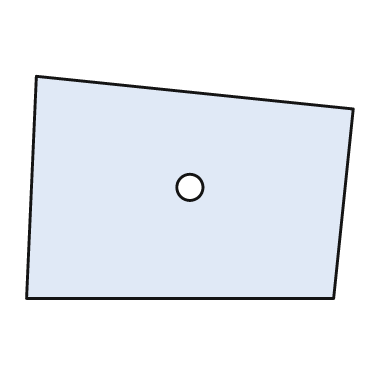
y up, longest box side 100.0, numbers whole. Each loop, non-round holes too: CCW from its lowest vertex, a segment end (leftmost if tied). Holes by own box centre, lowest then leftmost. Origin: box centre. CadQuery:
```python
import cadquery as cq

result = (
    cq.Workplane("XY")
    .moveTo(-50.0, -34.0)
    .lineTo(44.0, -34.0)
    .lineTo(50.0, 24.0)
    .lineTo(-47.0, 34.0)
    .close()
    .moveTo(0.0, 0.0)
    .circle(4.0)
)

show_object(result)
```